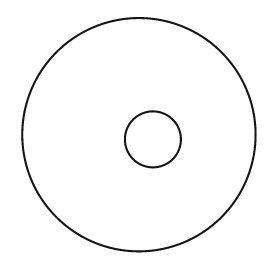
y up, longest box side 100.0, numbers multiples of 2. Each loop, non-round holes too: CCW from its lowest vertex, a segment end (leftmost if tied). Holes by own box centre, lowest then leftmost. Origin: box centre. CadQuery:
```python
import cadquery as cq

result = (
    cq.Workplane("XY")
    .moveTo(0.0, 0.0)
    .circle(50.0)
    .moveTo(6.0, -2.0)
    .circle(12.0)
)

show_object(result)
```